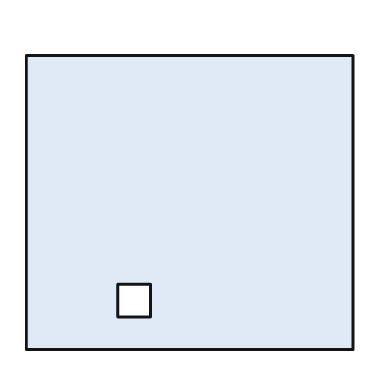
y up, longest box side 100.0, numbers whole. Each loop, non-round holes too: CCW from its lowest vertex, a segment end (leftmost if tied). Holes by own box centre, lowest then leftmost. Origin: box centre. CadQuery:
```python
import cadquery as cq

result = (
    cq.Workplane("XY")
    .moveTo(-50.0, -45.0)
    .lineTo(50.0, -45.0)
    .lineTo(50.0, 45.0)
    .lineTo(-50.0, 45.0)
    .close()
    .moveTo(-22.0, -35.0)
    .lineTo(-12.0, -35.0)
    .lineTo(-12.0, -25.0)
    .lineTo(-22.0, -25.0)
    .close()
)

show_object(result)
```